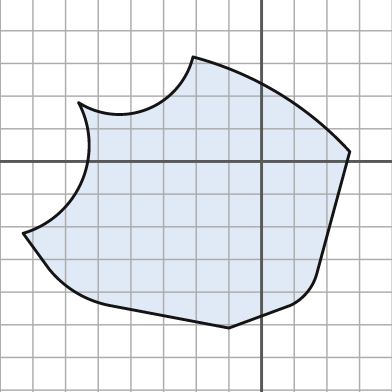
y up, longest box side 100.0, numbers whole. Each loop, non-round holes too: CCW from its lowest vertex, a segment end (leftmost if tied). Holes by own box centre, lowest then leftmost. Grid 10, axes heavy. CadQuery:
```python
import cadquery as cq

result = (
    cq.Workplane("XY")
    .moveTo(-10.0, -51.0)
    .lineTo(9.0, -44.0)
    .threePointArc((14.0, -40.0), (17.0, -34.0))
    .lineTo(27.0, 3.0)
    .threePointArc((5.0, 21.0), (-21.0, 32.0))
    .threePointArc((-35.0, 16.0), (-56.0, 18.0))
    .threePointArc((-55.0, -6.0), (-73.0, -22.0))
    .lineTo(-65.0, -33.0)
    .threePointArc((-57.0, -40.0), (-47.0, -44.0))
    .close()
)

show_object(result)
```